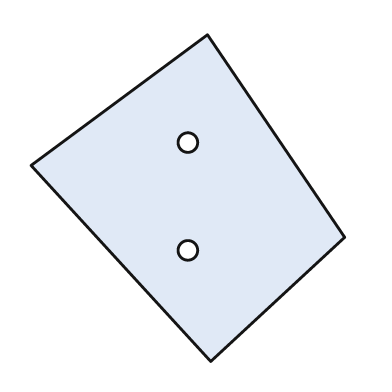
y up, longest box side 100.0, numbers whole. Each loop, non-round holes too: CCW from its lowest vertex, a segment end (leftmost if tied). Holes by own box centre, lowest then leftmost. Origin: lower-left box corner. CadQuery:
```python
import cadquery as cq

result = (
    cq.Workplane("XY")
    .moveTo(55.0, 0.0)
    .lineTo(96.0, 38.0)
    .lineTo(54.0, 100.0)
    .lineTo(0.0, 60.0)
    .close()
    .moveTo(48.0, 34.0)
    .circle(3.0)
    .moveTo(48.0, 67.0)
    .circle(3.0)
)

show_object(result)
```